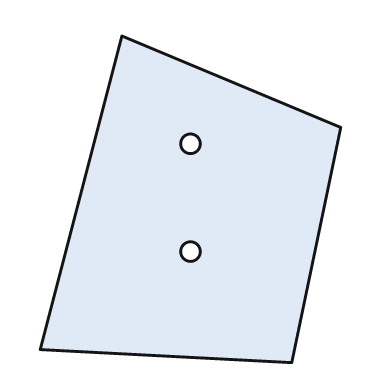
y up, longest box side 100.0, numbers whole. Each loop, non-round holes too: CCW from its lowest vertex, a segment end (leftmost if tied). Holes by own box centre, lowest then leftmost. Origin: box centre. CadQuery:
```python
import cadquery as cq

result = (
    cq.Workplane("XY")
    .moveTo(31.0, -50.0)
    .lineTo(46.0, 22.0)
    .lineTo(-21.0, 50.0)
    .lineTo(-46.0, -46.0)
    .close()
    .moveTo(0.0, -16.0)
    .circle(3.0)
    .moveTo(0.0, 17.0)
    .circle(3.0)
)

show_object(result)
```